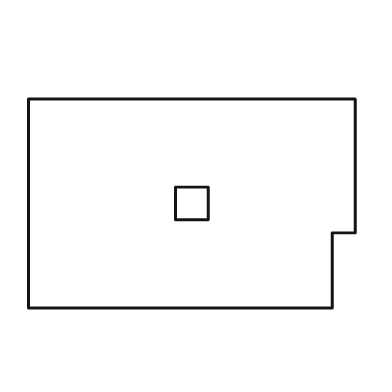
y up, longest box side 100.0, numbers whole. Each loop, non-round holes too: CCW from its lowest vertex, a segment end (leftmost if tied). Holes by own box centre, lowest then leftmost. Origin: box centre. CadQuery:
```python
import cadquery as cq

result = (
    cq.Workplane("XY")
    .moveTo(-50.0, -32.0)
    .lineTo(43.0, -32.0)
    .lineTo(43.0, -9.0)
    .lineTo(50.0, -9.0)
    .lineTo(50.0, 32.0)
    .lineTo(-50.0, 32.0)
    .close()
    .moveTo(-5.0, -5.0)
    .lineTo(5.0, -5.0)
    .lineTo(5.0, 5.0)
    .lineTo(-5.0, 5.0)
    .close()
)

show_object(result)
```